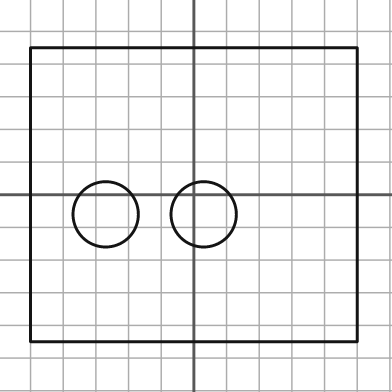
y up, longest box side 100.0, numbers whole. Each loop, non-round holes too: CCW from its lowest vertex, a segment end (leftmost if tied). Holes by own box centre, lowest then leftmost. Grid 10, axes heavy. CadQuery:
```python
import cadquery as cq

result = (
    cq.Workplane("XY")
    .moveTo(-50.0, -45.0)
    .lineTo(50.0, -45.0)
    .lineTo(50.0, 45.0)
    .lineTo(-50.0, 45.0)
    .close()
    .moveTo(-27.0, -6.0)
    .circle(10.0)
    .moveTo(3.0, -6.0)
    .circle(10.0)
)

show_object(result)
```